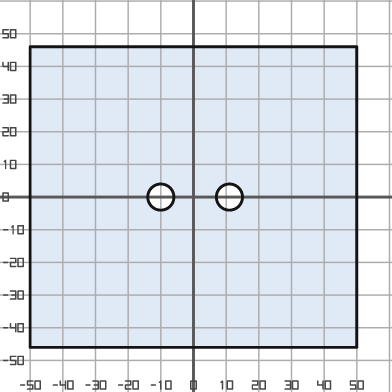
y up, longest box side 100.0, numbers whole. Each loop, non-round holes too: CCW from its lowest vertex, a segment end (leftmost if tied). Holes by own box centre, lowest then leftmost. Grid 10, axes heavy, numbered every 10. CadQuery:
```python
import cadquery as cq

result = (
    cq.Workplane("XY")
    .moveTo(-50.0, -46.0)
    .lineTo(50.0, -46.0)
    .lineTo(50.0, 46.0)
    .lineTo(-50.0, 46.0)
    .close()
    .moveTo(-10.0, 0.0)
    .circle(4.0)
    .moveTo(11.0, 0.0)
    .circle(4.0)
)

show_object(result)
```